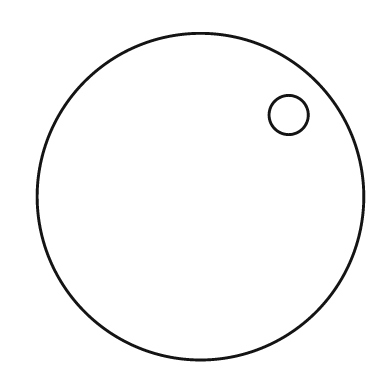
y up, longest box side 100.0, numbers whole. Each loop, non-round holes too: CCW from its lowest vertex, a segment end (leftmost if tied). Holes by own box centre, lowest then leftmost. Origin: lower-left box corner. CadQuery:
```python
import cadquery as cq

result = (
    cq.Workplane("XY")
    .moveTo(50.0, 50.0)
    .circle(50.0)
    .moveTo(77.0, 75.0)
    .circle(6.0)
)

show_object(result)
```